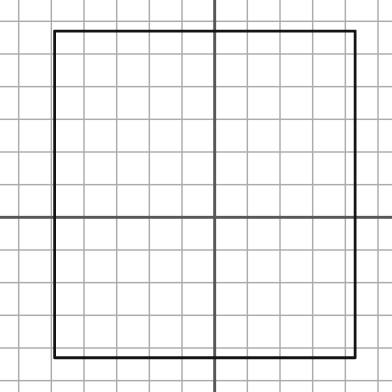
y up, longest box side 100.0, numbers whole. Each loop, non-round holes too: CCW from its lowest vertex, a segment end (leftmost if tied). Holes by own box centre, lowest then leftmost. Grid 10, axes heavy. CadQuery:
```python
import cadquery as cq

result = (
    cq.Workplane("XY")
    .moveTo(-49.0, -43.0)
    .lineTo(43.0, -43.0)
    .lineTo(43.0, 57.0)
    .lineTo(-49.0, 57.0)
    .close()
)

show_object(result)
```